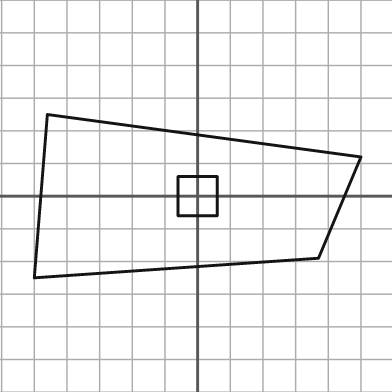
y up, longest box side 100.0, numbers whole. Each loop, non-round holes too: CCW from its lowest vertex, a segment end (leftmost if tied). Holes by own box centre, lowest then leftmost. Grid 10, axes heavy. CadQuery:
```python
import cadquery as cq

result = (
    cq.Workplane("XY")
    .moveTo(-50.0, -25.0)
    .lineTo(37.0, -19.0)
    .lineTo(50.0, 12.0)
    .lineTo(-46.0, 25.0)
    .close()
    .moveTo(-6.0, -6.0)
    .lineTo(6.0, -6.0)
    .lineTo(6.0, 6.0)
    .lineTo(-6.0, 6.0)
    .close()
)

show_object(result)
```